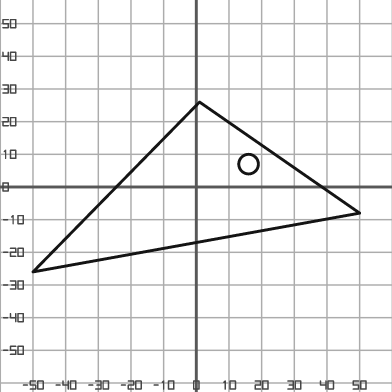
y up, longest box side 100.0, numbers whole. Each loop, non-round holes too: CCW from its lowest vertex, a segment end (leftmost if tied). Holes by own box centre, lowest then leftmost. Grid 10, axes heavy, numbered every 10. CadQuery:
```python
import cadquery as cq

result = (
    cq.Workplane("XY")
    .moveTo(-50.0, -26.0)
    .lineTo(50.0, -8.0)
    .lineTo(1.0, 26.0)
    .close()
    .moveTo(16.0, 7.0)
    .circle(3.0)
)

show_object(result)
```